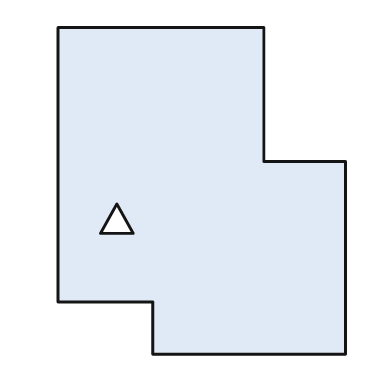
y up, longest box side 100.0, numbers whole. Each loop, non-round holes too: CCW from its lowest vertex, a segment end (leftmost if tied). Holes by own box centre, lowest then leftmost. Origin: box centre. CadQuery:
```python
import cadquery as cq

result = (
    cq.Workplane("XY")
    .moveTo(-15.0, -50.0)
    .lineTo(44.0, -50.0)
    .lineTo(44.0, 9.0)
    .lineTo(19.0, 9.0)
    .lineTo(19.0, 50.0)
    .lineTo(-44.0, 50.0)
    .lineTo(-44.0, -34.0)
    .lineTo(-15.0, -34.0)
    .close()
    .moveTo(-31.0, -13.0)
    .lineTo(-21.0, -13.0)
    .lineTo(-26.0, -4.0)
    .close()
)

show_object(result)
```